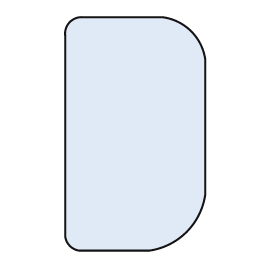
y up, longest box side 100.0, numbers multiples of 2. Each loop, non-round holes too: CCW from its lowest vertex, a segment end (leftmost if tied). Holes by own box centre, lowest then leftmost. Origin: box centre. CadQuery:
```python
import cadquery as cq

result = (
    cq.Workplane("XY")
    .moveTo(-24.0, -50.0)
    .lineTo(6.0, -50.0)
    .threePointArc((22.0, -42.0), (30.0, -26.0))
    .lineTo(30.0, 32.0)
    .threePointArc((24.0, 44.0), (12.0, 50.0))
    .lineTo(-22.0, 50.0)
    .threePointArc((-28.0, 48.0), (-30.0, 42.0))
    .lineTo(-30.0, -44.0)
    .threePointArc((-28.0, -48.0), (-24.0, -50.0))
    .close()
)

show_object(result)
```